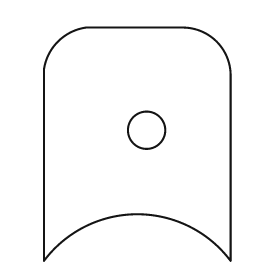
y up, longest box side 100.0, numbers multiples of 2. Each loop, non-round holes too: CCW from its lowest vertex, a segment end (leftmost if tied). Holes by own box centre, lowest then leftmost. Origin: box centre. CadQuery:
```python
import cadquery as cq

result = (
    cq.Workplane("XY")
    .moveTo(-40.0, -50.0)
    .threePointArc((0.0, -30.0), (40.0, -50.0))
    .lineTo(40.0, 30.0)
    .threePointArc((34.0, 44.0), (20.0, 50.0))
    .lineTo(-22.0, 50.0)
    .threePointArc((-34.0, 44.0), (-40.0, 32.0))
    .close()
    .moveTo(4.0, 6.0)
    .circle(8.0)
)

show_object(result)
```